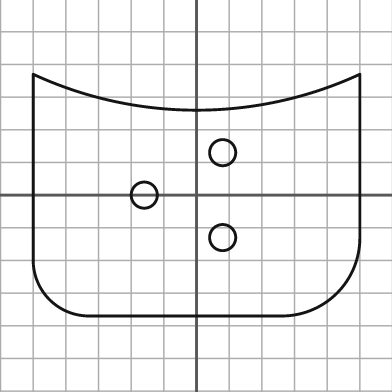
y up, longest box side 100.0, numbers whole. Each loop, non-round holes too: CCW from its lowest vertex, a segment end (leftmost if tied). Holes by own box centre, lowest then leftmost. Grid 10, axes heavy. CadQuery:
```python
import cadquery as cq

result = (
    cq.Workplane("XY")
    .moveTo(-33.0, -37.0)
    .lineTo(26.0, -37.0)
    .threePointArc((43.0, -30.0), (50.0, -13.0))
    .lineTo(50.0, 37.0)
    .threePointArc((0.0, 26.0), (-50.0, 37.0))
    .lineTo(-50.0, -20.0)
    .threePointArc((-45.0, -32.0), (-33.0, -37.0))
    .close()
    .moveTo(8.0, -13.0)
    .circle(4.0)
    .moveTo(-16.0, 0.0)
    .circle(4.0)
    .moveTo(8.0, 13.0)
    .circle(4.0)
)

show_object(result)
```